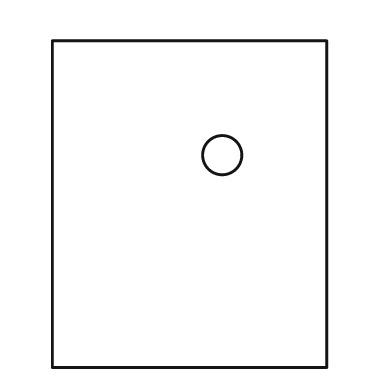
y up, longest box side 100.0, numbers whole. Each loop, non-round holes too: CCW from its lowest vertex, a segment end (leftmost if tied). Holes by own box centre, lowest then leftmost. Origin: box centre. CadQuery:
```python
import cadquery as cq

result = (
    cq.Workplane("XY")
    .moveTo(-42.0, -50.0)
    .lineTo(42.0, -50.0)
    .lineTo(42.0, 50.0)
    .lineTo(-42.0, 50.0)
    .close()
    .moveTo(10.0, 15.0)
    .circle(6.0)
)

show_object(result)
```